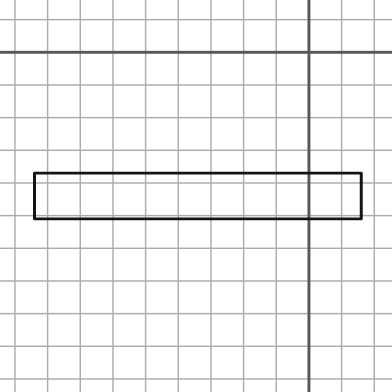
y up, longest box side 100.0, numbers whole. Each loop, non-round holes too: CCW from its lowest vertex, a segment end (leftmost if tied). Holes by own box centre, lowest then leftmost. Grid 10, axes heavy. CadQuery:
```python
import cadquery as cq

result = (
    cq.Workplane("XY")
    .moveTo(-84.0, -51.0)
    .lineTo(16.0, -51.0)
    .lineTo(16.0, -37.0)
    .lineTo(-84.0, -37.0)
    .close()
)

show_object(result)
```